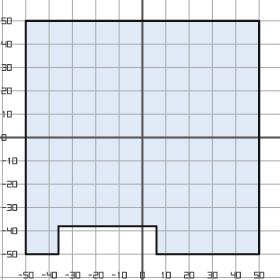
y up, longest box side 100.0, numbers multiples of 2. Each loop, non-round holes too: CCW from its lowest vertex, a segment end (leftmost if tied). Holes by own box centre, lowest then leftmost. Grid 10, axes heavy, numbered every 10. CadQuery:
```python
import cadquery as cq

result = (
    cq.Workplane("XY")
    .moveTo(-50.0, -50.0)
    .lineTo(-36.0, -50.0)
    .lineTo(-36.0, -38.0)
    .lineTo(6.0, -38.0)
    .lineTo(6.0, -50.0)
    .lineTo(50.0, -50.0)
    .lineTo(50.0, 50.0)
    .lineTo(-50.0, 50.0)
    .close()
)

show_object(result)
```